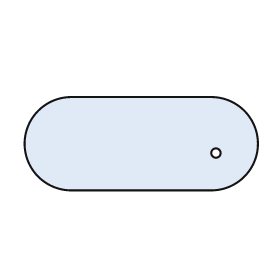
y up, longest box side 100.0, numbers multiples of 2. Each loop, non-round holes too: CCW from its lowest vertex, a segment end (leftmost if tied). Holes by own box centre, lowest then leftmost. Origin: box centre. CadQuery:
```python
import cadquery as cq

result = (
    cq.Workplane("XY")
    .moveTo(-30.0, -20.0)
    .lineTo(30.0, -20.0)
    .threePointArc((50.0, 0.0), (30.0, 20.0))
    .lineTo(-30.0, 20.0)
    .threePointArc((-50.0, 0.0), (-30.0, -20.0))
    .close()
    .moveTo(32.0, -4.0)
    .circle(2.0)
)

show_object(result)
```